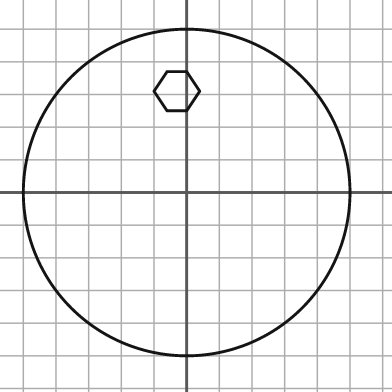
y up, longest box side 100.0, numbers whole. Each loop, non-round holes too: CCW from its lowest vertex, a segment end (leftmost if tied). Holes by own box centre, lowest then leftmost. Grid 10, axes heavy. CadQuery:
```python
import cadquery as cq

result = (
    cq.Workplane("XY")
    .moveTo(0.0, 0.0)
    .circle(50.0)
    .moveTo(-6.0, 25.0)
    .lineTo(0.0, 25.0)
    .lineTo(4.0, 31.0)
    .lineTo(0.0, 37.0)
    .lineTo(-6.0, 37.0)
    .lineTo(-10.0, 31.0)
    .close()
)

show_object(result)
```